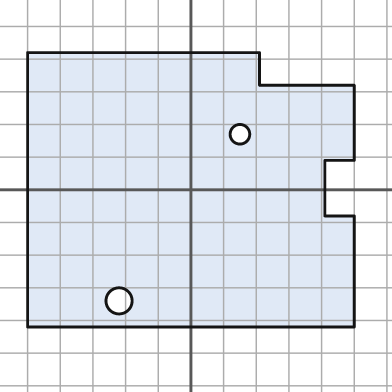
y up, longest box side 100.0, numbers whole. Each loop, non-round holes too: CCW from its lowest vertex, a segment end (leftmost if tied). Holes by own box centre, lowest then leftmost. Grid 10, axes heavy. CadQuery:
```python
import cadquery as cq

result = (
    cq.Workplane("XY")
    .moveTo(-50.0, -42.0)
    .lineTo(50.0, -42.0)
    .lineTo(50.0, -8.0)
    .lineTo(41.0, -8.0)
    .lineTo(41.0, 9.0)
    .lineTo(50.0, 9.0)
    .lineTo(50.0, 32.0)
    .lineTo(21.0, 32.0)
    .lineTo(21.0, 42.0)
    .lineTo(-50.0, 42.0)
    .close()
    .moveTo(-22.0, -34.0)
    .circle(4.0)
    .moveTo(15.0, 17.0)
    .circle(3.0)
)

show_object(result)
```